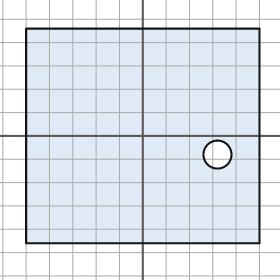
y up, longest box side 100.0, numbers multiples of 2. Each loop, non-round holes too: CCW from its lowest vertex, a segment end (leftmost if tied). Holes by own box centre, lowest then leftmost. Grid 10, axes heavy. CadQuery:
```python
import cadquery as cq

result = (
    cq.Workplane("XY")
    .moveTo(-50.0, -46.0)
    .lineTo(50.0, -46.0)
    .lineTo(50.0, 46.0)
    .lineTo(-50.0, 46.0)
    .close()
    .moveTo(32.0, -8.0)
    .circle(6.0)
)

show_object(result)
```